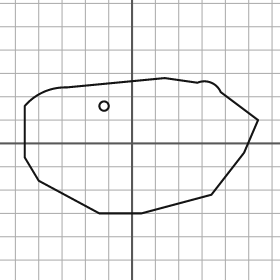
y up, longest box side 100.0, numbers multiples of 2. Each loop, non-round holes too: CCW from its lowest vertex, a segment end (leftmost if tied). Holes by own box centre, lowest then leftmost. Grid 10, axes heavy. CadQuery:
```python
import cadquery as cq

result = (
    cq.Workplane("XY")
    .moveTo(-14.0, -30.0)
    .lineTo(4.0, -30.0)
    .lineTo(34.0, -22.0)
    .lineTo(48.0, -4.0)
    .lineTo(54.0, 10.0)
    .lineTo(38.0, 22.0)
    .threePointArc((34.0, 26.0), (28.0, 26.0))
    .lineTo(14.0, 28.0)
    .lineTo(-28.0, 24.0)
    .threePointArc((-38.0, 22.0), (-46.0, 16.0))
    .lineTo(-46.0, -6.0)
    .lineTo(-40.0, -16.0)
    .close()
    .moveTo(-12.0, 16.0)
    .circle(2.0)
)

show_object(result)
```